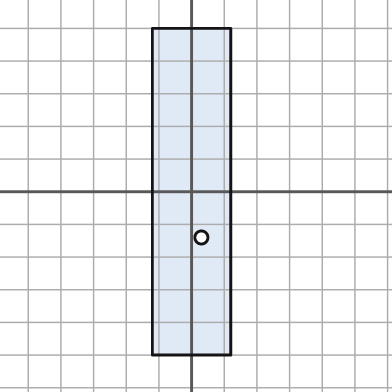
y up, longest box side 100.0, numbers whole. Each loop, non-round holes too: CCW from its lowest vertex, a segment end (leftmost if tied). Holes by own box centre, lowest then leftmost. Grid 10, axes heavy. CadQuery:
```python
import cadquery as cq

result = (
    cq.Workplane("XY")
    .moveTo(-12.0, -50.0)
    .lineTo(12.0, -50.0)
    .lineTo(12.0, 50.0)
    .lineTo(-12.0, 50.0)
    .close()
    .moveTo(3.0, -14.0)
    .circle(2.0)
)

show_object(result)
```